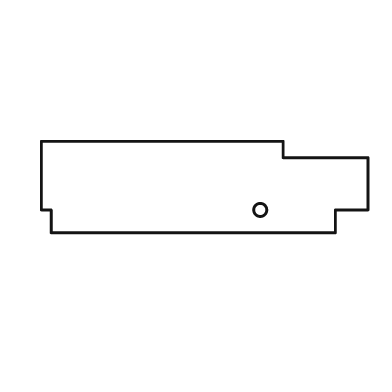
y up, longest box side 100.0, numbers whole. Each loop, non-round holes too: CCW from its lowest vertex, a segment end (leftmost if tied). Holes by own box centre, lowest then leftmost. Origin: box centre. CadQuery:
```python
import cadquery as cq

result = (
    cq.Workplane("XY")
    .moveTo(-47.0, -14.0)
    .lineTo(40.0, -14.0)
    .lineTo(40.0, -7.0)
    .lineTo(50.0, -7.0)
    .lineTo(50.0, 9.0)
    .lineTo(24.0, 9.0)
    .lineTo(24.0, 14.0)
    .lineTo(-50.0, 14.0)
    .lineTo(-50.0, -7.0)
    .lineTo(-47.0, -7.0)
    .close()
    .moveTo(17.0, -7.0)
    .circle(2.0)
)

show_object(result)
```